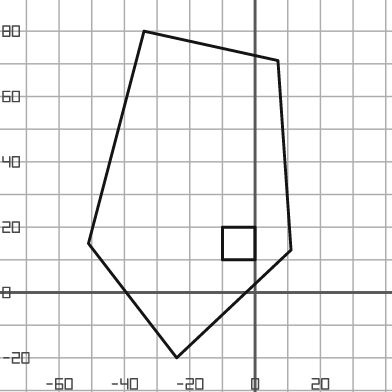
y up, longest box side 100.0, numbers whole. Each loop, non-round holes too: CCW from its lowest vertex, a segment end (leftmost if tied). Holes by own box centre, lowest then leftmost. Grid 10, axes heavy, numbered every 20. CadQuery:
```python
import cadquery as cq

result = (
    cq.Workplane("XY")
    .moveTo(-24.0, -20.0)
    .lineTo(11.0, 13.0)
    .lineTo(7.0, 71.0)
    .lineTo(-34.0, 80.0)
    .lineTo(-51.0, 15.0)
    .close()
    .moveTo(-10.0, 10.0)
    .lineTo(0.0, 10.0)
    .lineTo(0.0, 20.0)
    .lineTo(-10.0, 20.0)
    .close()
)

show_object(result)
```